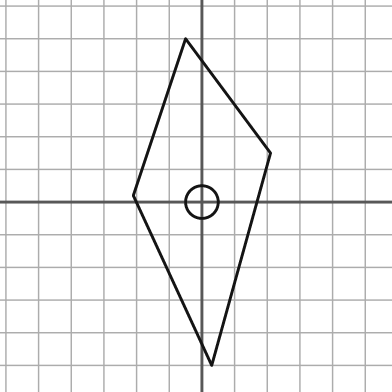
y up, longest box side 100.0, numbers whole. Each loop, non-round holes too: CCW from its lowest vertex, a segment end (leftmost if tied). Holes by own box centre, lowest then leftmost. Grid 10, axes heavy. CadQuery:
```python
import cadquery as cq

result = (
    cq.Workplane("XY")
    .moveTo(3.0, -50.0)
    .lineTo(21.0, 15.0)
    .lineTo(-5.0, 50.0)
    .lineTo(-21.0, 2.0)
    .close()
    .moveTo(0.0, 0.0)
    .circle(5.0)
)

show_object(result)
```